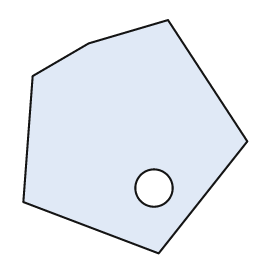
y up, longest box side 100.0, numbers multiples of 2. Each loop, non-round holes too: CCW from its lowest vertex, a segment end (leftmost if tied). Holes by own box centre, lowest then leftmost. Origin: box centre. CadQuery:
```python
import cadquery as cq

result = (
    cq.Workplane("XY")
    .moveTo(10.0, -50.0)
    .lineTo(48.0, -2.0)
    .lineTo(14.0, 50.0)
    .lineTo(-20.0, 40.0)
    .lineTo(-44.0, 26.0)
    .lineTo(-48.0, -28.0)
    .close()
    .moveTo(8.0, -22.0)
    .circle(8.0)
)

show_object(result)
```